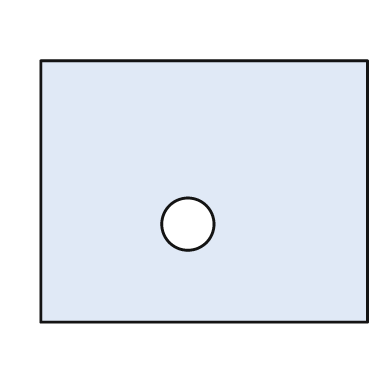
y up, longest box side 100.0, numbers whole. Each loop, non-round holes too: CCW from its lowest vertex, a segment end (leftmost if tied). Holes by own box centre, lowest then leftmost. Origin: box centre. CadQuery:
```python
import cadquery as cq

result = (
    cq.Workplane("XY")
    .moveTo(-50.0, -40.0)
    .lineTo(50.0, -40.0)
    .lineTo(50.0, 40.0)
    .lineTo(-50.0, 40.0)
    .close()
    .moveTo(-5.0, -10.0)
    .circle(8.0)
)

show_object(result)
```